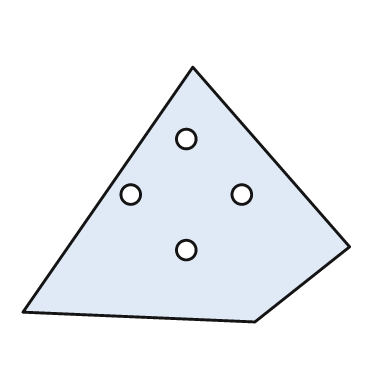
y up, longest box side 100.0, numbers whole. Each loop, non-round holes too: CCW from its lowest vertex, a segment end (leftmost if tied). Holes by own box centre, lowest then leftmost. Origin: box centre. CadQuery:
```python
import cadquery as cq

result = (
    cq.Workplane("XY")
    .moveTo(21.0, -39.0)
    .lineTo(50.0, -16.0)
    .lineTo(2.0, 39.0)
    .lineTo(-50.0, -36.0)
    .close()
    .moveTo(0.0, -17.0)
    .circle(3.0)
    .moveTo(-17.0, 0.0)
    .circle(3.0)
    .moveTo(17.0, 0.0)
    .circle(3.0)
    .moveTo(0.0, 17.0)
    .circle(3.0)
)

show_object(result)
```